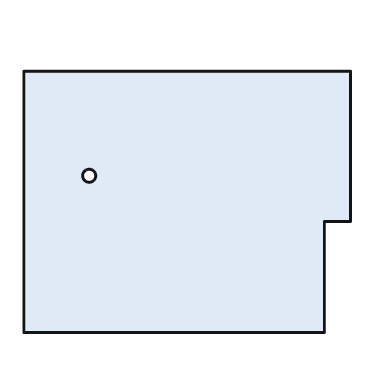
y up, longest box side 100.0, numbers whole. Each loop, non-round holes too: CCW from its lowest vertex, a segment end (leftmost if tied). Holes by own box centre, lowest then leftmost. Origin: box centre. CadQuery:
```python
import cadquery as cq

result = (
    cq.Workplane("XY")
    .moveTo(-50.0, -40.0)
    .lineTo(42.0, -40.0)
    .lineTo(42.0, -6.0)
    .lineTo(50.0, -6.0)
    .lineTo(50.0, 40.0)
    .lineTo(-50.0, 40.0)
    .close()
    .moveTo(-30.0, 8.0)
    .circle(2.0)
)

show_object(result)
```